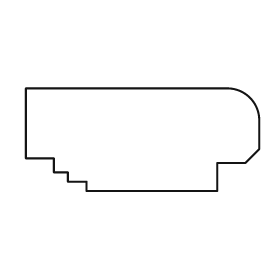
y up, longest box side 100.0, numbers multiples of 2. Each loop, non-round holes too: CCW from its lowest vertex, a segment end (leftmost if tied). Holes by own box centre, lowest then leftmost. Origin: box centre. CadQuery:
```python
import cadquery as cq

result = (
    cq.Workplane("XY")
    .moveTo(-24.0, -22.0)
    .lineTo(32.0, -22.0)
    .lineTo(32.0, -10.0)
    .lineTo(44.0, -10.0)
    .lineTo(50.0, -4.0)
    .lineTo(50.0, 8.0)
    .threePointArc((46.0, 18.0), (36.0, 22.0))
    .lineTo(-50.0, 22.0)
    .lineTo(-50.0, -8.0)
    .lineTo(-38.0, -8.0)
    .lineTo(-38.0, -14.0)
    .lineTo(-32.0, -14.0)
    .lineTo(-32.0, -18.0)
    .lineTo(-24.0, -18.0)
    .close()
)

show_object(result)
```